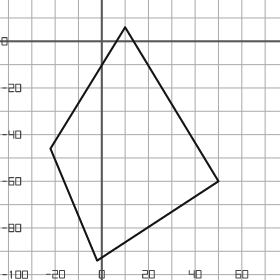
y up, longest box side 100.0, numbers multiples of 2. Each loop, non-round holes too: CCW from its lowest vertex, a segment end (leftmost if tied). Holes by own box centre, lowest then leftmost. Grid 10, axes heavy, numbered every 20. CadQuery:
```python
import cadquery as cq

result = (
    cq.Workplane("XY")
    .moveTo(-2.0, -94.0)
    .lineTo(50.0, -60.0)
    .lineTo(10.0, 6.0)
    .lineTo(-22.0, -46.0)
    .close()
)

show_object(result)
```